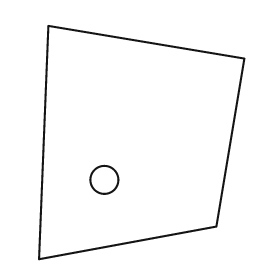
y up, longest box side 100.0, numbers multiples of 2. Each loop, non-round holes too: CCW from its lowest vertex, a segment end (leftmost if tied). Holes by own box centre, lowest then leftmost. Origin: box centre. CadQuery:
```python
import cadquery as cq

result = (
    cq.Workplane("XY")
    .moveTo(-44.0, -50.0)
    .lineTo(32.0, -36.0)
    .lineTo(44.0, 36.0)
    .lineTo(-40.0, 50.0)
    .close()
    .moveTo(-16.0, -16.0)
    .circle(6.0)
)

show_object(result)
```